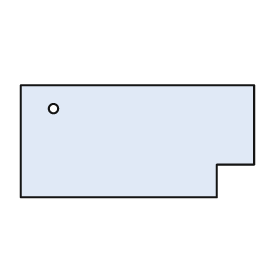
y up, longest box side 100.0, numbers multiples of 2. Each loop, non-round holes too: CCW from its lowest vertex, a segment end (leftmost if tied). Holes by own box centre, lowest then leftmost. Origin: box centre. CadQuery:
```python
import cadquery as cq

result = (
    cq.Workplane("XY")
    .moveTo(-50.0, -24.0)
    .lineTo(34.0, -24.0)
    .lineTo(34.0, -10.0)
    .lineTo(50.0, -10.0)
    .lineTo(50.0, 24.0)
    .lineTo(-50.0, 24.0)
    .close()
    .moveTo(-36.0, 14.0)
    .circle(2.0)
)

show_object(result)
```